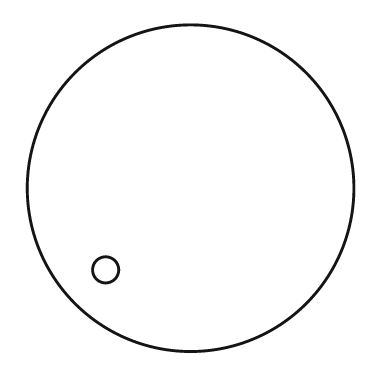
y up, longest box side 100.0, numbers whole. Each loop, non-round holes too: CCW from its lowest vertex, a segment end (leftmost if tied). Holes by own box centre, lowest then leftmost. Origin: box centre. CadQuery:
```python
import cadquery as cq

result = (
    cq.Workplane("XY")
    .moveTo(0.0, 0.0)
    .circle(50.0)
    .moveTo(-26.0, -25.0)
    .circle(4.0)
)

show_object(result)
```